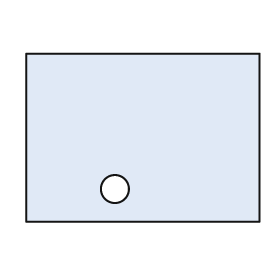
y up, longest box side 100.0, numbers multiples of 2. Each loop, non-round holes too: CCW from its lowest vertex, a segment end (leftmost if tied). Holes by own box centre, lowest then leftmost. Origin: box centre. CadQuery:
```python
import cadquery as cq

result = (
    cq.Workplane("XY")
    .moveTo(-50.0, -36.0)
    .lineTo(50.0, -36.0)
    .lineTo(50.0, 36.0)
    .lineTo(-50.0, 36.0)
    .close()
    .moveTo(-12.0, -22.0)
    .circle(6.0)
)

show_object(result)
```